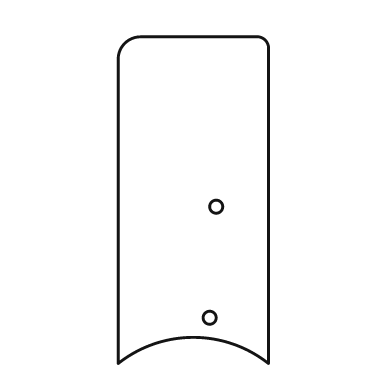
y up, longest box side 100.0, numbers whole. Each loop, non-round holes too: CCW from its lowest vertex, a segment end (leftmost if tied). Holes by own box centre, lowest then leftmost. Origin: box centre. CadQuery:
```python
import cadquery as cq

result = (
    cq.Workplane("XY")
    .moveTo(-23.0, -50.0)
    .threePointArc((0.0, -42.0), (23.0, -50.0))
    .lineTo(23.0, 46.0)
    .threePointArc((22.0, 49.0), (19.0, 50.0))
    .lineTo(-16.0, 50.0)
    .threePointArc((-21.0, 48.0), (-23.0, 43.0))
    .close()
    .moveTo(5.0, -36.0)
    .circle(2.0)
    .moveTo(7.0, -2.0)
    .circle(2.0)
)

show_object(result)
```